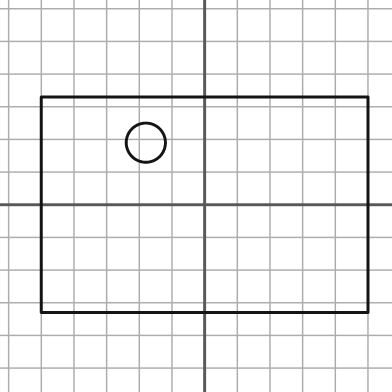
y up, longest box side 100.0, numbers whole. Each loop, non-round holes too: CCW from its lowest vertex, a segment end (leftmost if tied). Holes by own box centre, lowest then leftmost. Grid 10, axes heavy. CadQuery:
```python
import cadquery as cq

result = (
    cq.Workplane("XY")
    .moveTo(-50.0, -33.0)
    .lineTo(50.0, -33.0)
    .lineTo(50.0, 33.0)
    .lineTo(-50.0, 33.0)
    .close()
    .moveTo(-18.0, 19.0)
    .circle(6.0)
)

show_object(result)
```